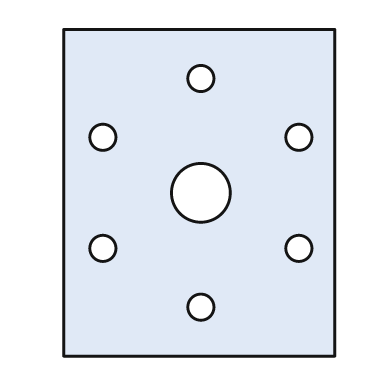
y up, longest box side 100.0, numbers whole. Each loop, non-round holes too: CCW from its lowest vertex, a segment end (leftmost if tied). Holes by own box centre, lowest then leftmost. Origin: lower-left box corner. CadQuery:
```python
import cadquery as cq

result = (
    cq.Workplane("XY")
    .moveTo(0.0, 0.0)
    .lineTo(83.0, 0.0)
    .lineTo(83.0, 100.0)
    .lineTo(0.0, 100.0)
    .close()
    .moveTo(42.0, 15.0)
    .circle(4.0)
    .moveTo(12.0, 33.0)
    .circle(4.0)
    .moveTo(72.0, 33.0)
    .circle(4.0)
    .moveTo(42.0, 50.0)
    .circle(9.0)
    .moveTo(12.0, 67.0)
    .circle(4.0)
    .moveTo(72.0, 67.0)
    .circle(4.0)
    .moveTo(42.0, 85.0)
    .circle(4.0)
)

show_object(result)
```